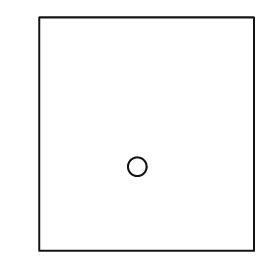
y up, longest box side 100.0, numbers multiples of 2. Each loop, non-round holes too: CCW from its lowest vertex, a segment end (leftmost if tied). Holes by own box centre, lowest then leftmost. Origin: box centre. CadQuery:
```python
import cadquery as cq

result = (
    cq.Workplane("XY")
    .moveTo(-46.0, -50.0)
    .lineTo(46.0, -50.0)
    .lineTo(46.0, 50.0)
    .lineTo(-46.0, 50.0)
    .close()
    .moveTo(-4.0, -14.0)
    .circle(4.0)
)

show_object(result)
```